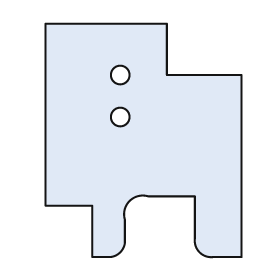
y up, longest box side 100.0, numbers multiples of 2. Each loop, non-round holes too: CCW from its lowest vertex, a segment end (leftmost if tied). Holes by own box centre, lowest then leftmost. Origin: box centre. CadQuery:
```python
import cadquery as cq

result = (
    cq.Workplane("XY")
    .moveTo(-22.0, -50.0)
    .lineTo(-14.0, -50.0)
    .threePointArc((-10.0, -48.0), (-8.0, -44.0))
    .lineTo(-8.0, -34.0)
    .threePointArc((-6.0, -26.0), (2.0, -24.0))
    .lineTo(22.0, -24.0)
    .lineTo(22.0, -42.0)
    .threePointArc((24.0, -48.0), (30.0, -50.0))
    .lineTo(42.0, -50.0)
    .lineTo(42.0, 28.0)
    .lineTo(10.0, 28.0)
    .lineTo(10.0, 50.0)
    .lineTo(-42.0, 50.0)
    .lineTo(-42.0, -28.0)
    .lineTo(-22.0, -28.0)
    .close()
    .moveTo(-10.0, 10.0)
    .circle(4.0)
    .moveTo(-10.0, 28.0)
    .circle(4.0)
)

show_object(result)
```